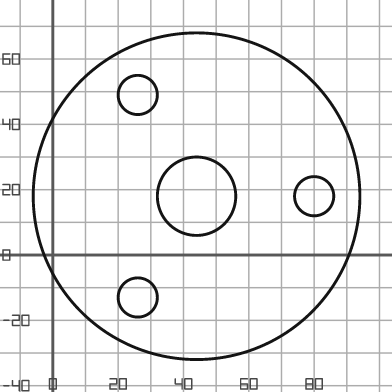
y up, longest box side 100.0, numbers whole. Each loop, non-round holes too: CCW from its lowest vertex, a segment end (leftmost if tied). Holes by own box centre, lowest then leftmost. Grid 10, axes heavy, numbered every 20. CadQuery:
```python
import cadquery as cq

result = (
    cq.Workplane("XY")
    .moveTo(44.0, 18.0)
    .circle(50.0)
    .moveTo(26.0, -13.0)
    .circle(6.0)
    .moveTo(44.0, 18.0)
    .circle(12.0)
    .moveTo(80.0, 18.0)
    .circle(6.0)
    .moveTo(26.0, 49.0)
    .circle(6.0)
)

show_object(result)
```